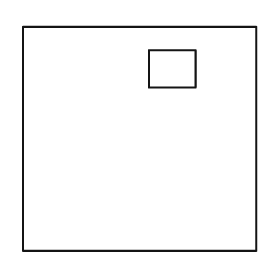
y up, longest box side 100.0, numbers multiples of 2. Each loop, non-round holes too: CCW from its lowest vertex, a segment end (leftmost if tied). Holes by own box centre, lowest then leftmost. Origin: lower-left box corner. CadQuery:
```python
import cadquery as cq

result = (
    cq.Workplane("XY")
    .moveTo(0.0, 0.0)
    .lineTo(100.0, 0.0)
    .lineTo(100.0, 96.0)
    .lineTo(0.0, 96.0)
    .close()
    .moveTo(54.0, 70.0)
    .lineTo(74.0, 70.0)
    .lineTo(74.0, 86.0)
    .lineTo(54.0, 86.0)
    .close()
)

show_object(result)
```